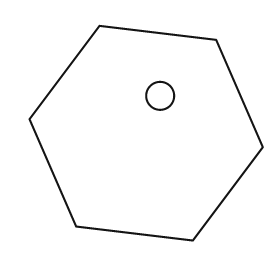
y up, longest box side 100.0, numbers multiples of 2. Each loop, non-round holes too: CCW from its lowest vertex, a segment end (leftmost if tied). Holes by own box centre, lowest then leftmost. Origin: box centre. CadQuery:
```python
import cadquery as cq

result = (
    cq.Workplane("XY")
    .moveTo(20.0, -46.0)
    .lineTo(50.0, -6.0)
    .lineTo(30.0, 40.0)
    .lineTo(-20.0, 46.0)
    .lineTo(-50.0, 6.0)
    .lineTo(-30.0, -40.0)
    .close()
    .moveTo(6.0, 16.0)
    .circle(6.0)
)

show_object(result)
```